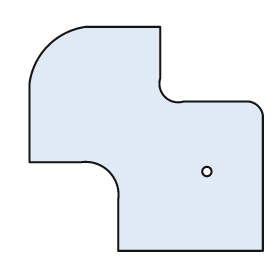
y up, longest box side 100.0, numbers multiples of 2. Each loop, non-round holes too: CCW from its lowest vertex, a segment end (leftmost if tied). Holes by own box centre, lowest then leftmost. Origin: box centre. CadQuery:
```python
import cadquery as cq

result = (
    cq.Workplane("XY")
    .moveTo(-12.0, -48.0)
    .lineTo(50.0, -48.0)
    .lineTo(50.0, 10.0)
    .threePointArc((48.0, 14.0), (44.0, 16.0))
    .lineTo(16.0, 16.0)
    .threePointArc((8.0, 18.0), (6.0, 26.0))
    .lineTo(6.0, 48.0)
    .lineTo(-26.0, 48.0)
    .threePointArc((-42.0, 40.0), (-50.0, 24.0))
    .lineTo(-50.0, -10.0)
    .lineTo(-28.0, -10.0)
    .threePointArc((-16.0, -14.0), (-12.0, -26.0))
    .close()
    .moveTo(26.0, -14.0)
    .circle(2.0)
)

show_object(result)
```